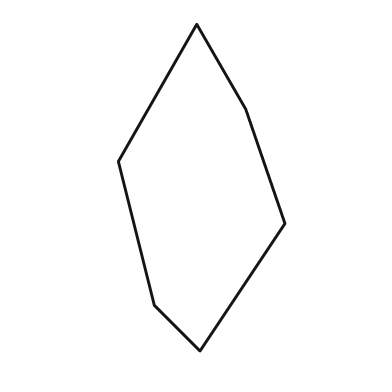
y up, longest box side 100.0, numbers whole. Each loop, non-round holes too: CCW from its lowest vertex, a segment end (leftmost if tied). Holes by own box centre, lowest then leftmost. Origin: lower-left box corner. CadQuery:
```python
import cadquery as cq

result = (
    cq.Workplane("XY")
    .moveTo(25.0, 0.0)
    .lineTo(51.0, 39.0)
    .lineTo(39.0, 74.0)
    .lineTo(24.0, 100.0)
    .lineTo(0.0, 58.0)
    .lineTo(11.0, 14.0)
    .close()
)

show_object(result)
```